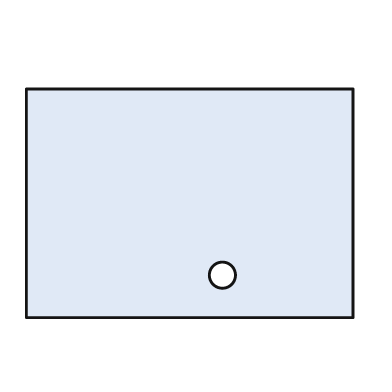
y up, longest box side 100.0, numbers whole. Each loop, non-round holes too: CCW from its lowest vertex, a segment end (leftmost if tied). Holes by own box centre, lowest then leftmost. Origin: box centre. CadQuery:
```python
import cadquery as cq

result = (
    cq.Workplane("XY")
    .moveTo(-50.0, -35.0)
    .lineTo(50.0, -35.0)
    .lineTo(50.0, 35.0)
    .lineTo(-50.0, 35.0)
    .close()
    .moveTo(10.0, -22.0)
    .circle(4.0)
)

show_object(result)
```